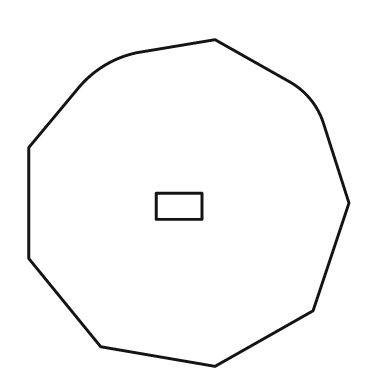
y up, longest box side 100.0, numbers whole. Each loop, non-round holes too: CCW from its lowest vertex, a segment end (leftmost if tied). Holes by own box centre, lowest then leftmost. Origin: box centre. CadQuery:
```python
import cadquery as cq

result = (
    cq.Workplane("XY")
    .moveTo(8.0, -50.0)
    .lineTo(38.0, -33.0)
    .lineTo(49.0, 0.0)
    .lineTo(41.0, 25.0)
    .threePointArc((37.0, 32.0), (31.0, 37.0))
    .lineTo(8.0, 50.0)
    .lineTo(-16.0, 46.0)
    .threePointArc((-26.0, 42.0), (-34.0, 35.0))
    .lineTo(-49.0, 17.0)
    .lineTo(-49.0, -17.0)
    .lineTo(-27.0, -44.0)
    .close()
    .moveTo(-10.0, -5.0)
    .lineTo(4.0, -5.0)
    .lineTo(4.0, 3.0)
    .lineTo(-10.0, 3.0)
    .close()
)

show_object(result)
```